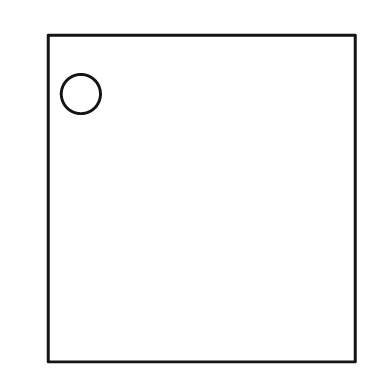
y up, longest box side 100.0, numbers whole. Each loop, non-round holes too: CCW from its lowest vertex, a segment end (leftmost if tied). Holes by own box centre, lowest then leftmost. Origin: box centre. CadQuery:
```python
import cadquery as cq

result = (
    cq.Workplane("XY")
    .moveTo(-47.0, -50.0)
    .lineTo(47.0, -50.0)
    .lineTo(47.0, 50.0)
    .lineTo(-47.0, 50.0)
    .close()
    .moveTo(-37.0, 32.0)
    .circle(6.0)
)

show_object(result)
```